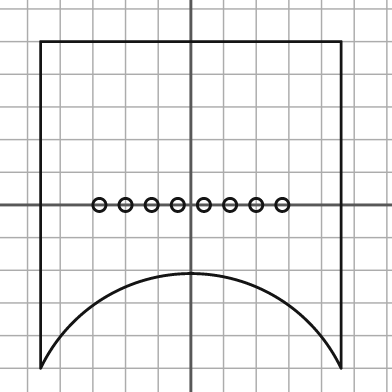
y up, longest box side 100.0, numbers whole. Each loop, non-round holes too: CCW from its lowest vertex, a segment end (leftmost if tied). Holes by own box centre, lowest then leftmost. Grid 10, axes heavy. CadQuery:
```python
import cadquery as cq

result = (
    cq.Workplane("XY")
    .moveTo(-46.0, -50.0)
    .threePointArc((0.0, -21.0), (46.0, -50.0))
    .lineTo(46.0, 50.0)
    .lineTo(-46.0, 50.0)
    .close()
    .moveTo(-28.0, 0.0)
    .circle(2.0)
    .moveTo(-20.0, 0.0)
    .circle(2.0)
    .moveTo(-12.0, 0.0)
    .circle(2.0)
    .moveTo(-4.0, 0.0)
    .circle(2.0)
    .moveTo(4.0, 0.0)
    .circle(2.0)
    .moveTo(12.0, 0.0)
    .circle(2.0)
    .moveTo(20.0, 0.0)
    .circle(2.0)
    .moveTo(28.0, 0.0)
    .circle(2.0)
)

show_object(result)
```